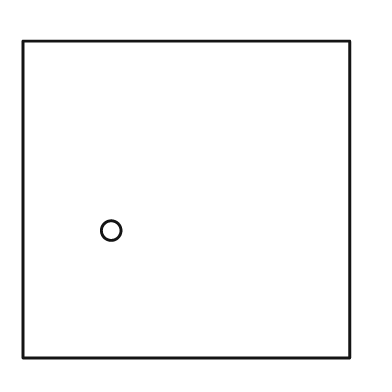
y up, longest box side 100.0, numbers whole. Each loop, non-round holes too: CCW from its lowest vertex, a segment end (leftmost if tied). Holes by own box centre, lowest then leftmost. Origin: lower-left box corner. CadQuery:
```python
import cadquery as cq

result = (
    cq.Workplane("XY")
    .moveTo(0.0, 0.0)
    .lineTo(100.0, 0.0)
    .lineTo(100.0, 97.0)
    .lineTo(0.0, 97.0)
    .close()
    .moveTo(27.0, 39.0)
    .circle(3.0)
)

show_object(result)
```